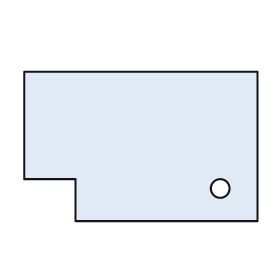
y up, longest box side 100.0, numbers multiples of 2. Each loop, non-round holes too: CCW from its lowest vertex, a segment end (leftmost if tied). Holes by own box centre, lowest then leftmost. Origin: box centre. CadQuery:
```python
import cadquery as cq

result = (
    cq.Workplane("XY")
    .moveTo(-28.0, -32.0)
    .lineTo(50.0, -32.0)
    .lineTo(50.0, 32.0)
    .lineTo(-50.0, 32.0)
    .lineTo(-50.0, -14.0)
    .lineTo(-28.0, -14.0)
    .close()
    .moveTo(34.0, -18.0)
    .circle(4.0)
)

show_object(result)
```